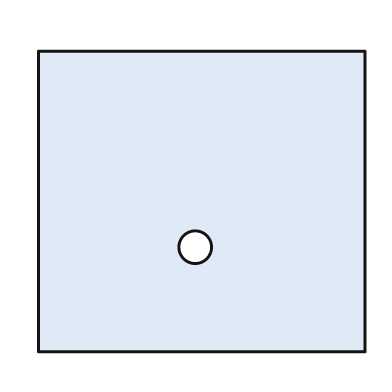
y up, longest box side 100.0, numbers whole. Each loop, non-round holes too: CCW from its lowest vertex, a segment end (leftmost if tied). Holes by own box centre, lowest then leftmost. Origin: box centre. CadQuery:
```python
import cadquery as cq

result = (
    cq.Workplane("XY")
    .moveTo(-50.0, -46.0)
    .lineTo(50.0, -46.0)
    .lineTo(50.0, 46.0)
    .lineTo(-50.0, 46.0)
    .close()
    .moveTo(-2.0, -14.0)
    .circle(5.0)
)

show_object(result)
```